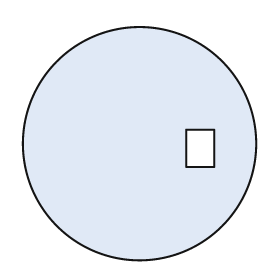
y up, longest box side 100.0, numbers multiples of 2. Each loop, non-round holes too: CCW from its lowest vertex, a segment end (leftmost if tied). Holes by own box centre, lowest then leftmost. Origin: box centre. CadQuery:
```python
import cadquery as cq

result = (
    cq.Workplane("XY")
    .moveTo(0.0, 0.0)
    .circle(50.0)
    .moveTo(20.0, -10.0)
    .lineTo(32.0, -10.0)
    .lineTo(32.0, 6.0)
    .lineTo(20.0, 6.0)
    .close()
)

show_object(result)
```